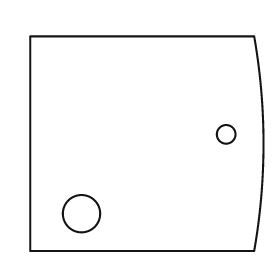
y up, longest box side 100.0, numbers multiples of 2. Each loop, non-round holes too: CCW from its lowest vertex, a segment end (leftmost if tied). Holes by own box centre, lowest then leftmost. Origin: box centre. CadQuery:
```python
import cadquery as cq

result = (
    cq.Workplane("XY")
    .moveTo(-50.0, -46.0)
    .lineTo(46.0, -46.0)
    .threePointArc((50.0, 0.0), (46.0, 46.0))
    .lineTo(-50.0, 46.0)
    .close()
    .moveTo(-28.0, -30.0)
    .circle(8.0)
    .moveTo(34.0, 4.0)
    .circle(4.0)
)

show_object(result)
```